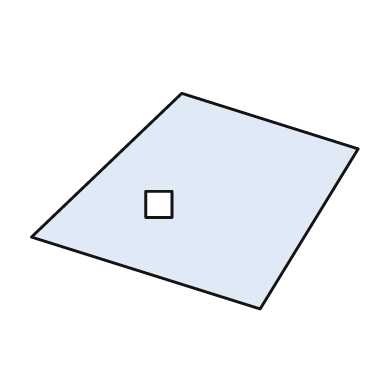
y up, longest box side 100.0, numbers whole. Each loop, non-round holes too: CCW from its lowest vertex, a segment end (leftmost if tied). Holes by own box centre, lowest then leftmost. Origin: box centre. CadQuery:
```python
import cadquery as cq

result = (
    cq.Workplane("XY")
    .moveTo(20.0, -33.0)
    .lineTo(50.0, 16.0)
    .lineTo(-4.0, 33.0)
    .lineTo(-50.0, -11.0)
    .close()
    .moveTo(-15.0, -5.0)
    .lineTo(-7.0, -5.0)
    .lineTo(-7.0, 3.0)
    .lineTo(-15.0, 3.0)
    .close()
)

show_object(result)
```